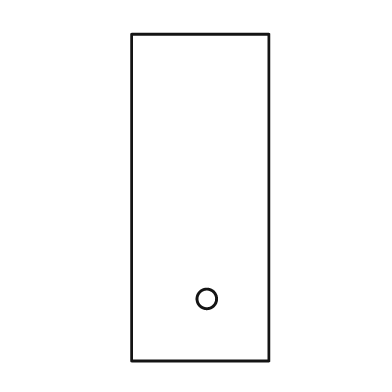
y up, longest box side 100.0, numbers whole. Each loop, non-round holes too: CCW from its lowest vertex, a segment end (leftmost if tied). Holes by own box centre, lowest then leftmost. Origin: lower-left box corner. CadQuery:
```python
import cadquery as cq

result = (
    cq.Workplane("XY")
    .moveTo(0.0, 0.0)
    .lineTo(42.0, 0.0)
    .lineTo(42.0, 100.0)
    .lineTo(0.0, 100.0)
    .close()
    .moveTo(23.0, 19.0)
    .circle(3.0)
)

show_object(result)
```